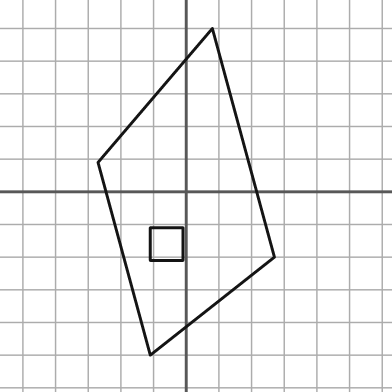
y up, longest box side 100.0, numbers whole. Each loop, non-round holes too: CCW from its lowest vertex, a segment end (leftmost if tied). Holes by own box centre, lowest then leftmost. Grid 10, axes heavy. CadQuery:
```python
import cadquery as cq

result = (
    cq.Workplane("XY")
    .moveTo(-11.0, -50.0)
    .lineTo(27.0, -20.0)
    .lineTo(8.0, 50.0)
    .lineTo(-27.0, 9.0)
    .close()
    .moveTo(-11.0, -21.0)
    .lineTo(-1.0, -21.0)
    .lineTo(-1.0, -11.0)
    .lineTo(-11.0, -11.0)
    .close()
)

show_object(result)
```